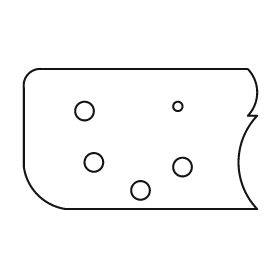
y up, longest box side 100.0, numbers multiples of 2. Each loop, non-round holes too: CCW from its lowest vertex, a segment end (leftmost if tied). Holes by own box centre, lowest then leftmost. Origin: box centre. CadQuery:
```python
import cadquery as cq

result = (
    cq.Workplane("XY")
    .moveTo(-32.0, -30.0)
    .lineTo(50.0, -30.0)
    .threePointArc((42.0, -10.0), (50.0, 10.0))
    .lineTo(46.0, 10.0)
    .threePointArc((50.0, 20.0), (46.0, 30.0))
    .lineTo(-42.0, 30.0)
    .threePointArc((-48.0, 28.0), (-50.0, 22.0))
    .lineTo(-50.0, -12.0)
    .threePointArc((-44.0, -24.0), (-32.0, -30.0))
    .close()
    .moveTo(0.0, -22.0)
    .circle(4.0)
    .moveTo(18.0, -12.0)
    .circle(4.0)
    .moveTo(-20.0, -10.0)
    .circle(4.0)
    .moveTo(-24.0, 12.0)
    .circle(4.0)
    .moveTo(16.0, 14.0)
    .circle(2.0)
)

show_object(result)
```